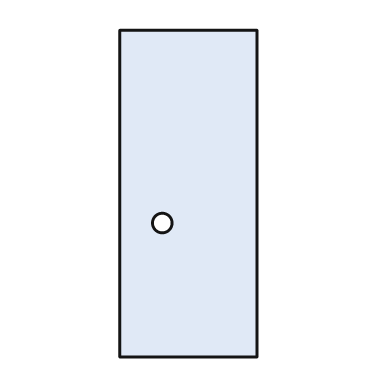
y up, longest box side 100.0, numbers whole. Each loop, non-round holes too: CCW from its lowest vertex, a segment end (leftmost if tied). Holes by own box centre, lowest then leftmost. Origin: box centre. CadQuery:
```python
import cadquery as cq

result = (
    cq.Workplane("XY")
    .moveTo(-21.0, -50.0)
    .lineTo(21.0, -50.0)
    .lineTo(21.0, 50.0)
    .lineTo(-21.0, 50.0)
    .close()
    .moveTo(-8.0, -9.0)
    .circle(3.0)
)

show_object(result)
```